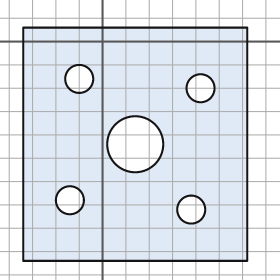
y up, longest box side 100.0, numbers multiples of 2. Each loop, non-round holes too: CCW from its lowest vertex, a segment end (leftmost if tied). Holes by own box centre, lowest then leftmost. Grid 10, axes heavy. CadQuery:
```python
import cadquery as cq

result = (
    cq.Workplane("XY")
    .moveTo(-34.0, -94.0)
    .lineTo(62.0, -94.0)
    .lineTo(62.0, 6.0)
    .lineTo(-34.0, 6.0)
    .close()
    .moveTo(38.0, -72.0)
    .circle(6.0)
    .moveTo(-14.0, -68.0)
    .circle(6.0)
    .moveTo(14.0, -44.0)
    .circle(12.0)
    .moveTo(42.0, -20.0)
    .circle(6.0)
    .moveTo(-10.0, -16.0)
    .circle(6.0)
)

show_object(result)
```